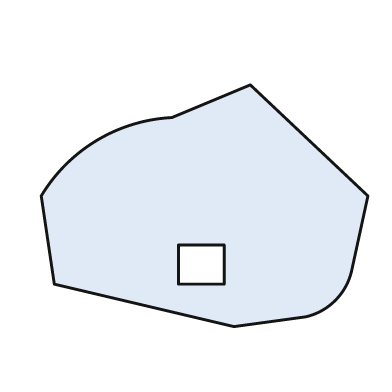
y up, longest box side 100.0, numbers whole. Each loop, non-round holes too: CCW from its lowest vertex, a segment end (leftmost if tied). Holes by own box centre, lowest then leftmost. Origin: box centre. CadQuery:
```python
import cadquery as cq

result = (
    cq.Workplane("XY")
    .moveTo(9.0, -37.0)
    .lineTo(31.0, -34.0)
    .threePointArc((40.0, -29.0), (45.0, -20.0))
    .lineTo(50.0, 3.0)
    .lineTo(14.0, 37.0)
    .lineTo(-10.0, 27.0)
    .threePointArc((-33.0, 20.0), (-50.0, 3.0))
    .lineTo(-46.0, -24.0)
    .close()
    .moveTo(-8.0, -24.0)
    .lineTo(6.0, -24.0)
    .lineTo(6.0, -12.0)
    .lineTo(-8.0, -12.0)
    .close()
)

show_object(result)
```